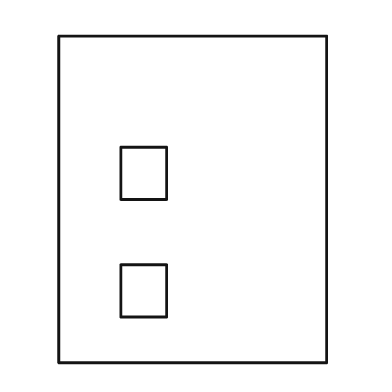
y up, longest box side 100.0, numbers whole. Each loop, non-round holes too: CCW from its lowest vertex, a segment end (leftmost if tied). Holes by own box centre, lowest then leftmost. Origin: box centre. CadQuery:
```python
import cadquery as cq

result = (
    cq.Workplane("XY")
    .moveTo(-41.0, -50.0)
    .lineTo(41.0, -50.0)
    .lineTo(41.0, 50.0)
    .lineTo(-41.0, 50.0)
    .close()
    .moveTo(-22.0, -36.0)
    .lineTo(-8.0, -36.0)
    .lineTo(-8.0, -20.0)
    .lineTo(-22.0, -20.0)
    .close()
    .moveTo(-22.0, 0.0)
    .lineTo(-8.0, 0.0)
    .lineTo(-8.0, 16.0)
    .lineTo(-22.0, 16.0)
    .close()
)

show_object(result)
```